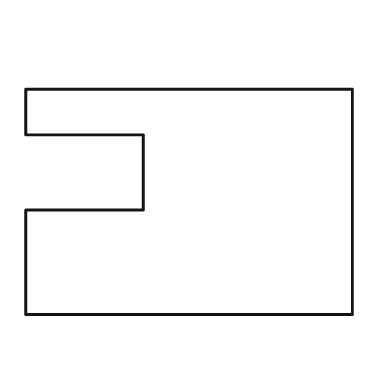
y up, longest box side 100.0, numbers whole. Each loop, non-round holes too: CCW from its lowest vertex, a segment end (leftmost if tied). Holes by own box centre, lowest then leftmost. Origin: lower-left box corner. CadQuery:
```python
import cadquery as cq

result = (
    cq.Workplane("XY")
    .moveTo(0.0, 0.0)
    .lineTo(100.0, 0.0)
    .lineTo(100.0, 69.0)
    .lineTo(0.0, 69.0)
    .lineTo(0.0, 55.0)
    .lineTo(36.0, 55.0)
    .lineTo(36.0, 32.0)
    .lineTo(0.0, 32.0)
    .close()
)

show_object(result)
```